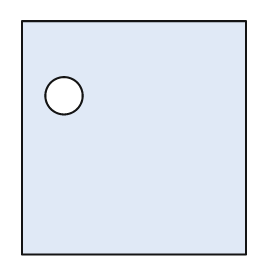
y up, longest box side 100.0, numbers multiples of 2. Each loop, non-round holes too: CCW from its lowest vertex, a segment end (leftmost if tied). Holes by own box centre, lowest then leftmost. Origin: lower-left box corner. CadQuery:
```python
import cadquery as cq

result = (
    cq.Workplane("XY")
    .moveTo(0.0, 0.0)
    .lineTo(96.0, 0.0)
    .lineTo(96.0, 100.0)
    .lineTo(0.0, 100.0)
    .close()
    .moveTo(18.0, 68.0)
    .circle(8.0)
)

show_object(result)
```